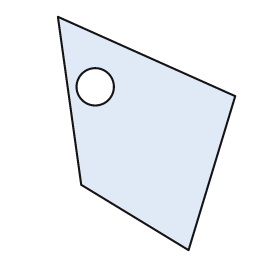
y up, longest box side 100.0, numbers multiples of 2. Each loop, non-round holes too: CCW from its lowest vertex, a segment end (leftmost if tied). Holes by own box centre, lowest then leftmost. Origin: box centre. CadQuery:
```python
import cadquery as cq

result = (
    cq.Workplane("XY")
    .moveTo(18.0, -50.0)
    .lineTo(38.0, 16.0)
    .lineTo(-38.0, 50.0)
    .lineTo(-28.0, -22.0)
    .close()
    .moveTo(-22.0, 20.0)
    .circle(8.0)
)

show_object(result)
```